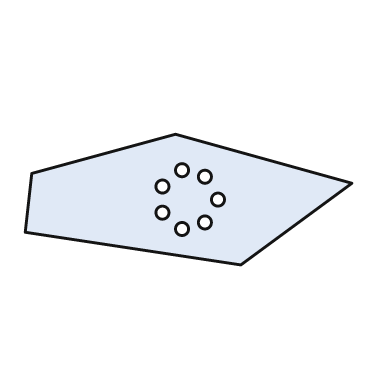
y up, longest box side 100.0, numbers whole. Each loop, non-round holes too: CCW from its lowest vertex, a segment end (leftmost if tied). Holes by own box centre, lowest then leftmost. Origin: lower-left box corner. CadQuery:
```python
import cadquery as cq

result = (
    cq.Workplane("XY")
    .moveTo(66.0, 0.0)
    .lineTo(100.0, 25.0)
    .lineTo(46.0, 40.0)
    .lineTo(2.0, 28.0)
    .lineTo(0.0, 10.0)
    .close()
    .moveTo(48.0, 11.0)
    .circle(2.0)
    .moveTo(55.0, 13.0)
    .circle(2.0)
    .moveTo(42.0, 16.0)
    .circle(2.0)
    .moveTo(59.0, 20.0)
    .circle(2.0)
    .moveTo(42.0, 24.0)
    .circle(2.0)
    .moveTo(55.0, 27.0)
    .circle(2.0)
    .moveTo(48.0, 29.0)
    .circle(2.0)
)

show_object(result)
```